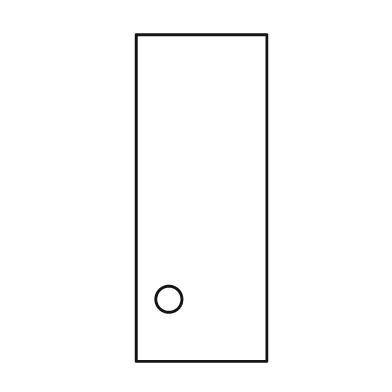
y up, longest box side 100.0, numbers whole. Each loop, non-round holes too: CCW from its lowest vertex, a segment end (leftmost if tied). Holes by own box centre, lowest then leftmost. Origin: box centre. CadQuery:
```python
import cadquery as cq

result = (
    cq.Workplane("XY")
    .moveTo(-20.0, -50.0)
    .lineTo(20.0, -50.0)
    .lineTo(20.0, 50.0)
    .lineTo(-20.0, 50.0)
    .close()
    .moveTo(-10.0, -31.0)
    .circle(4.0)
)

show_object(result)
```